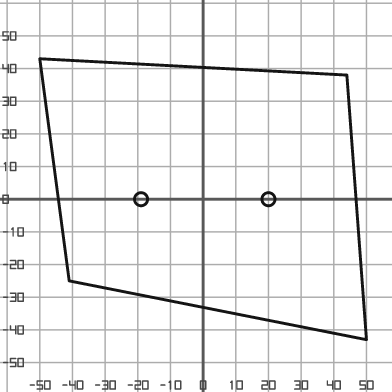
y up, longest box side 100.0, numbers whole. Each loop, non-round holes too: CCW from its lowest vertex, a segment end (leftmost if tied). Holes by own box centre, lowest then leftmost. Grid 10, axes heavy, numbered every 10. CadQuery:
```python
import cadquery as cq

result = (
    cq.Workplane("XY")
    .moveTo(50.0, -43.0)
    .lineTo(44.0, 38.0)
    .lineTo(-50.0, 43.0)
    .lineTo(-41.0, -25.0)
    .close()
    .moveTo(-19.0, 0.0)
    .circle(2.0)
    .moveTo(20.0, 0.0)
    .circle(2.0)
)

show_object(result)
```